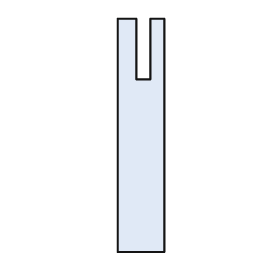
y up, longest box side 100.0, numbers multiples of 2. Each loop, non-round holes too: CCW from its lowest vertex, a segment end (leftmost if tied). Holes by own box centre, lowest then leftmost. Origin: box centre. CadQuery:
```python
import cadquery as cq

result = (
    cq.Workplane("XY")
    .moveTo(-10.0, -50.0)
    .lineTo(10.0, -50.0)
    .lineTo(10.0, 50.0)
    .lineTo(4.0, 50.0)
    .lineTo(4.0, 24.0)
    .lineTo(-2.0, 24.0)
    .lineTo(-2.0, 50.0)
    .lineTo(-10.0, 50.0)
    .close()
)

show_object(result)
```